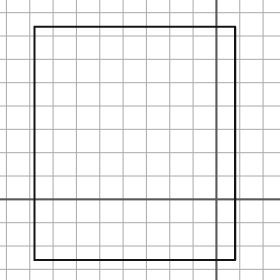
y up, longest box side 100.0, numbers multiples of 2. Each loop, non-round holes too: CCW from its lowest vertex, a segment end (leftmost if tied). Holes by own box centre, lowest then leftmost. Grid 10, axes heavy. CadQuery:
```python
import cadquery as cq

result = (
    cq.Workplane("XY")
    .moveTo(-78.0, -26.0)
    .lineTo(8.0, -26.0)
    .lineTo(8.0, 74.0)
    .lineTo(-78.0, 74.0)
    .close()
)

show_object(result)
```